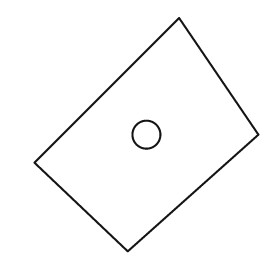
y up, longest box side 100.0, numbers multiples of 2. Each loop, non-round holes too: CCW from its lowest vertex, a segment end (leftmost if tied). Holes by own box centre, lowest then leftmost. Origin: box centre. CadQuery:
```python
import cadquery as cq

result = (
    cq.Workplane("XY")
    .moveTo(-8.0, -50.0)
    .lineTo(48.0, 0.0)
    .lineTo(14.0, 50.0)
    .lineTo(-48.0, -12.0)
    .close()
    .moveTo(0.0, 0.0)
    .circle(6.0)
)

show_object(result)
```